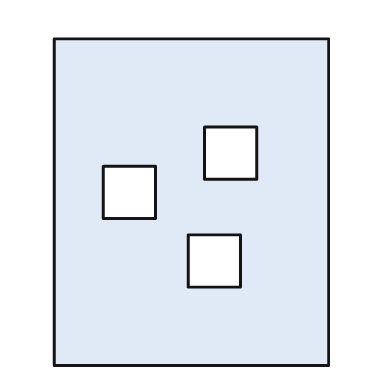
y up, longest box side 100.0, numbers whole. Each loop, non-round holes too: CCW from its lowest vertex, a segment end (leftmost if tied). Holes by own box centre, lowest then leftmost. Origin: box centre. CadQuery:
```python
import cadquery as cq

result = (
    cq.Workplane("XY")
    .moveTo(-42.0, -50.0)
    .lineTo(42.0, -50.0)
    .lineTo(42.0, 50.0)
    .lineTo(-42.0, 50.0)
    .close()
    .moveTo(-1.0, -26.0)
    .lineTo(15.0, -26.0)
    .lineTo(15.0, -10.0)
    .lineTo(-1.0, -10.0)
    .close()
    .moveTo(-27.0, -5.0)
    .lineTo(-11.0, -5.0)
    .lineTo(-11.0, 11.0)
    .lineTo(-27.0, 11.0)
    .close()
    .moveTo(4.0, 7.0)
    .lineTo(20.0, 7.0)
    .lineTo(20.0, 23.0)
    .lineTo(4.0, 23.0)
    .close()
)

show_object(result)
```